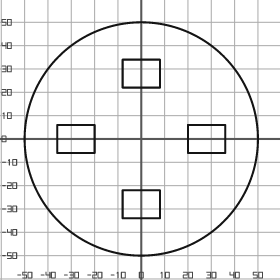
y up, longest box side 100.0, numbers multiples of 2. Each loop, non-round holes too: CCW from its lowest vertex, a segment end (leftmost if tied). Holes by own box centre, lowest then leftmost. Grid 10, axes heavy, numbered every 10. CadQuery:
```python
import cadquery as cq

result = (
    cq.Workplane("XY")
    .moveTo(0.0, 0.0)
    .circle(50.0)
    .moveTo(-8.0, -34.0)
    .lineTo(8.0, -34.0)
    .lineTo(8.0, -22.0)
    .lineTo(-8.0, -22.0)
    .close()
    .moveTo(-36.0, -6.0)
    .lineTo(-20.0, -6.0)
    .lineTo(-20.0, 6.0)
    .lineTo(-36.0, 6.0)
    .close()
    .moveTo(20.0, -6.0)
    .lineTo(36.0, -6.0)
    .lineTo(36.0, 6.0)
    .lineTo(20.0, 6.0)
    .close()
    .moveTo(-8.0, 22.0)
    .lineTo(8.0, 22.0)
    .lineTo(8.0, 34.0)
    .lineTo(-8.0, 34.0)
    .close()
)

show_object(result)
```